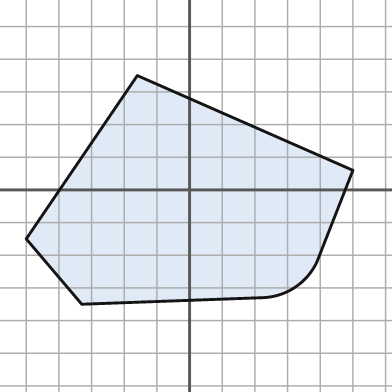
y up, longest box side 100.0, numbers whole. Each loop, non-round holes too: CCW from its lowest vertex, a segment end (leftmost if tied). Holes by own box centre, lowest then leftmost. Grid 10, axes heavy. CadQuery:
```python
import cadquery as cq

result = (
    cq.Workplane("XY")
    .moveTo(-33.0, -35.0)
    .lineTo(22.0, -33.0)
    .threePointArc((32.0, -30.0), (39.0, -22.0))
    .lineTo(50.0, 6.0)
    .lineTo(-16.0, 35.0)
    .lineTo(-50.0, -15.0)
    .close()
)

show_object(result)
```